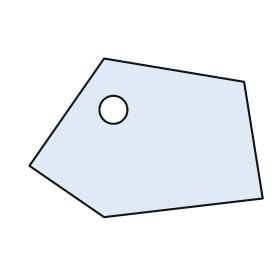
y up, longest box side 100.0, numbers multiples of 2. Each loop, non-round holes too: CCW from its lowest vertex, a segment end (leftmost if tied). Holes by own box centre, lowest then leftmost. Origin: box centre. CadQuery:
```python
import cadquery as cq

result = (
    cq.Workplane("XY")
    .moveTo(-18.0, -34.0)
    .lineTo(50.0, -26.0)
    .lineTo(42.0, 24.0)
    .lineTo(-18.0, 34.0)
    .lineTo(-50.0, -12.0)
    .close()
    .moveTo(-14.0, 12.0)
    .circle(6.0)
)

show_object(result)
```